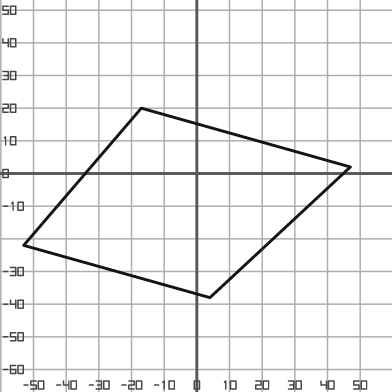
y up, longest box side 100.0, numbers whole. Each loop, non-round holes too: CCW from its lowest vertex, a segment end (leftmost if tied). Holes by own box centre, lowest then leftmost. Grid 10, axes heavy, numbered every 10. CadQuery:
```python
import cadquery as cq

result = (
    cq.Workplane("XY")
    .moveTo(4.0, -38.0)
    .lineTo(47.0, 2.0)
    .lineTo(-17.0, 20.0)
    .lineTo(-53.0, -22.0)
    .close()
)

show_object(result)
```